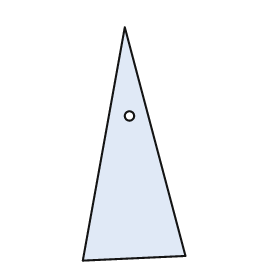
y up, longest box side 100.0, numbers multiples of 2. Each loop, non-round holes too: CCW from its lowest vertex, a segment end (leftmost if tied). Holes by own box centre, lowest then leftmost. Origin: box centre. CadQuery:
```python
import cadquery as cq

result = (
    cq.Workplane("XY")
    .moveTo(-22.0, -50.0)
    .lineTo(22.0, -48.0)
    .lineTo(-4.0, 50.0)
    .close()
    .moveTo(-2.0, 12.0)
    .circle(2.0)
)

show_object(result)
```